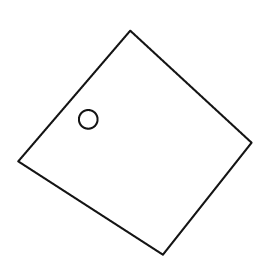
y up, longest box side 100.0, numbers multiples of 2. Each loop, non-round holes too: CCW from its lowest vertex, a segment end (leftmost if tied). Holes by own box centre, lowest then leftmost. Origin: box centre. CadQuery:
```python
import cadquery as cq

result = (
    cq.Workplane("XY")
    .moveTo(12.0, -48.0)
    .lineTo(50.0, 0.0)
    .lineTo(-2.0, 48.0)
    .lineTo(-50.0, -8.0)
    .close()
    .moveTo(-20.0, 10.0)
    .circle(4.0)
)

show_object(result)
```